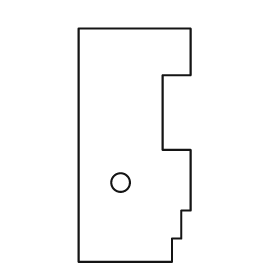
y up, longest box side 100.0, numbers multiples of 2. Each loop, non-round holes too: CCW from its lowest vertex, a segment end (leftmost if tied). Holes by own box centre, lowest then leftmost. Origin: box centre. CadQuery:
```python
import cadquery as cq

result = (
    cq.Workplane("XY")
    .moveTo(-24.0, -50.0)
    .lineTo(16.0, -50.0)
    .lineTo(16.0, -40.0)
    .lineTo(20.0, -40.0)
    .lineTo(20.0, -28.0)
    .lineTo(24.0, -28.0)
    .lineTo(24.0, -2.0)
    .lineTo(12.0, -2.0)
    .lineTo(12.0, 30.0)
    .lineTo(24.0, 30.0)
    .lineTo(24.0, 50.0)
    .lineTo(-24.0, 50.0)
    .close()
    .moveTo(-6.0, -16.0)
    .circle(4.0)
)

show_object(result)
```